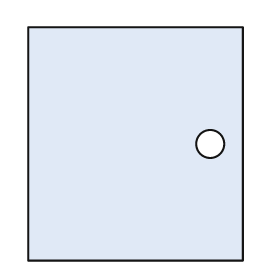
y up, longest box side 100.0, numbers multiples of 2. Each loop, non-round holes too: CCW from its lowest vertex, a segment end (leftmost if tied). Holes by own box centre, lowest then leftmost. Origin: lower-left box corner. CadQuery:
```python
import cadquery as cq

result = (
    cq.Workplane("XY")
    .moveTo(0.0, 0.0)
    .lineTo(92.0, 0.0)
    .lineTo(92.0, 100.0)
    .lineTo(0.0, 100.0)
    .close()
    .moveTo(78.0, 50.0)
    .circle(6.0)
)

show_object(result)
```